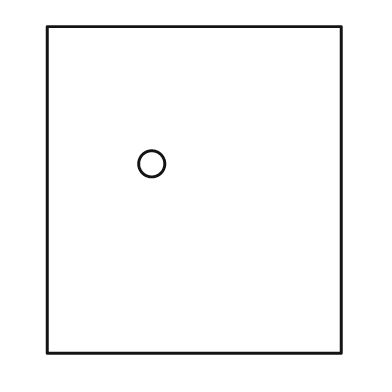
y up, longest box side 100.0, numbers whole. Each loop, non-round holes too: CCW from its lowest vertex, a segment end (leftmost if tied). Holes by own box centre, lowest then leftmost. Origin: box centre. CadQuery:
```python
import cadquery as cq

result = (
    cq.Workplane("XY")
    .moveTo(-45.0, -50.0)
    .lineTo(45.0, -50.0)
    .lineTo(45.0, 50.0)
    .lineTo(-45.0, 50.0)
    .close()
    .moveTo(-13.0, 8.0)
    .circle(4.0)
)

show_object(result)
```